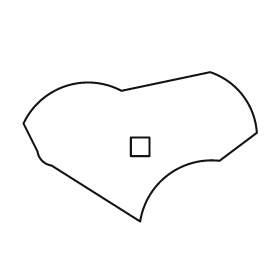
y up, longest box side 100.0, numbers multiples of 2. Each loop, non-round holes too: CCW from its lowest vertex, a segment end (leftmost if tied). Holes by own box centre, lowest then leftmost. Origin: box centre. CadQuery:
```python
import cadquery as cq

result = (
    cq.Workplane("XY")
    .moveTo(0.0, -32.0)
    .threePointArc((12.0, -12.0), (34.0, -6.0))
    .lineTo(50.0, 6.0)
    .threePointArc((44.0, 22.0), (30.0, 32.0))
    .lineTo(-8.0, 24.0)
    .threePointArc((-32.0, 26.0), (-50.0, 10.0))
    .lineTo(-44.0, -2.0)
    .threePointArc((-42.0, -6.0), (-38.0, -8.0))
    .close()
    .moveTo(-4.0, -4.0)
    .lineTo(4.0, -4.0)
    .lineTo(4.0, 4.0)
    .lineTo(-4.0, 4.0)
    .close()
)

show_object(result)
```